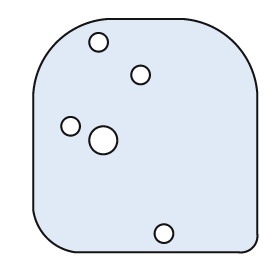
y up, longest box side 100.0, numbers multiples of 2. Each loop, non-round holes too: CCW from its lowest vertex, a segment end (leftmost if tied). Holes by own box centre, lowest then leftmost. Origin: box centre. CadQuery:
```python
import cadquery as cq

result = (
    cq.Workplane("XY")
    .moveTo(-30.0, -50.0)
    .lineTo(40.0, -50.0)
    .threePointArc((46.0, -48.0), (48.0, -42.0))
    .lineTo(48.0, 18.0)
    .threePointArc((38.0, 40.0), (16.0, 50.0))
    .lineTo(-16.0, 50.0)
    .threePointArc((-38.0, 40.0), (-48.0, 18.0))
    .lineTo(-48.0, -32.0)
    .threePointArc((-42.0, -44.0), (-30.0, -50.0))
    .close()
    .moveTo(8.0, -42.0)
    .circle(4.0)
    .moveTo(-18.0, -2.0)
    .circle(6.0)
    .moveTo(-32.0, 4.0)
    .circle(4.0)
    .moveTo(-2.0, 26.0)
    .circle(4.0)
    .moveTo(-20.0, 40.0)
    .circle(4.0)
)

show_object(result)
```